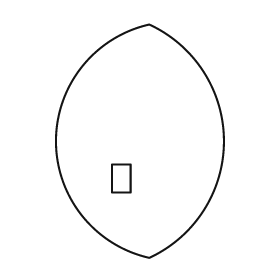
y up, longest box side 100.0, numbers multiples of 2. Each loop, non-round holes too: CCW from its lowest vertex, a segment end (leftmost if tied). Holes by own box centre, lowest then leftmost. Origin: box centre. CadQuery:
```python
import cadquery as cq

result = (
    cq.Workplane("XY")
    .moveTo(4.0, -50.0)
    .threePointArc((36.0, 0.0), (4.0, 50.0))
    .threePointArc((-36.0, 0.0), (4.0, -50.0))
    .close()
    .moveTo(-12.0, -22.0)
    .lineTo(-4.0, -22.0)
    .lineTo(-4.0, -10.0)
    .lineTo(-12.0, -10.0)
    .close()
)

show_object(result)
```